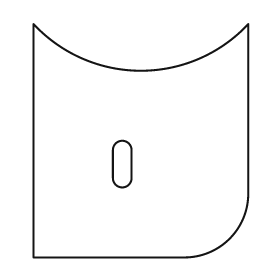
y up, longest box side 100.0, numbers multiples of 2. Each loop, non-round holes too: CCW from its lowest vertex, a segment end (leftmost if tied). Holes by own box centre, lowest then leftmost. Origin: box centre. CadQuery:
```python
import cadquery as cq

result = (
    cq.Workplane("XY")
    .moveTo(-46.0, -50.0)
    .lineTo(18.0, -50.0)
    .threePointArc((38.0, -42.0), (46.0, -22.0))
    .lineTo(46.0, 50.0)
    .threePointArc((0.0, 30.0), (-46.0, 50.0))
    .close()
    .moveTo(-12.0, -16.0)
    .threePointArc((-8.0, -20.0), (-4.0, -16.0))
    .lineTo(-4.0, -4.0)
    .threePointArc((-8.0, 0.0), (-12.0, -4.0))
    .close()
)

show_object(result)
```